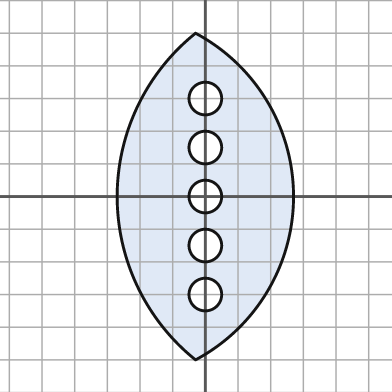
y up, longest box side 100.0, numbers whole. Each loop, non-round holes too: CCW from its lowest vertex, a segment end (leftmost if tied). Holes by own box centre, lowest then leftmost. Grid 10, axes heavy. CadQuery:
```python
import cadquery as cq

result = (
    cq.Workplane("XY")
    .moveTo(-3.0, -50.0)
    .threePointArc((27.0, 0.0), (-3.0, 50.0))
    .threePointArc((-27.0, 0.0), (-3.0, -50.0))
    .close()
    .moveTo(0.0, -30.0)
    .circle(5.0)
    .moveTo(0.0, -15.0)
    .circle(5.0)
    .moveTo(0.0, 0.0)
    .circle(5.0)
    .moveTo(0.0, 15.0)
    .circle(5.0)
    .moveTo(0.0, 30.0)
    .circle(5.0)
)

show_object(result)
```